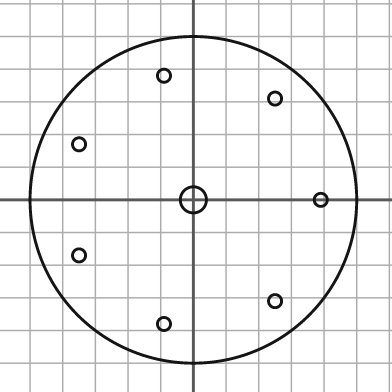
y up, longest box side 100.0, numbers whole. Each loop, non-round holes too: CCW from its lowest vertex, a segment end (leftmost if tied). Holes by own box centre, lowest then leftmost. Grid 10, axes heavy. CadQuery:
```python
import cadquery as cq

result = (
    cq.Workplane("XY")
    .moveTo(0.0, 0.0)
    .circle(50.0)
    .moveTo(-9.0, -38.0)
    .circle(2.0)
    .moveTo(25.0, -31.0)
    .circle(2.0)
    .moveTo(-35.0, -17.0)
    .circle(2.0)
    .moveTo(0.0, 0.0)
    .circle(4.0)
    .moveTo(39.0, 0.0)
    .circle(2.0)
    .moveTo(-35.0, 17.0)
    .circle(2.0)
    .moveTo(25.0, 31.0)
    .circle(2.0)
    .moveTo(-9.0, 38.0)
    .circle(2.0)
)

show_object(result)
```